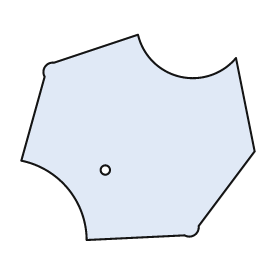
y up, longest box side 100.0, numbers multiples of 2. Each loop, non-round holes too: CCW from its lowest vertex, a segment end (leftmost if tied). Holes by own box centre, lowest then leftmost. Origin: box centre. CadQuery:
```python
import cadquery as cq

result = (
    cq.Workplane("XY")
    .moveTo(-22.0, -44.0)
    .lineTo(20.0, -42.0)
    .threePointArc((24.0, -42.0), (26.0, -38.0))
    .lineTo(50.0, -6.0)
    .lineTo(42.0, 34.0)
    .threePointArc((18.0, 26.0), (0.0, 44.0))
    .lineTo(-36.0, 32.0)
    .threePointArc((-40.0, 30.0), (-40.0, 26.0))
    .lineTo(-50.0, -10.0)
    .threePointArc((-30.0, -22.0), (-22.0, -44.0))
    .close()
    .moveTo(-14.0, -14.0)
    .circle(2.0)
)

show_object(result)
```